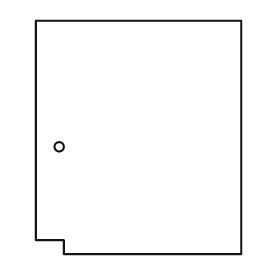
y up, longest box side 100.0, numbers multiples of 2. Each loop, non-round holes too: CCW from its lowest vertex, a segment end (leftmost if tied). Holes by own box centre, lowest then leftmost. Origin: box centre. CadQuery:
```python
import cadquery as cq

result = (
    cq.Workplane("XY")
    .moveTo(-32.0, -50.0)
    .lineTo(44.0, -50.0)
    .lineTo(44.0, 50.0)
    .lineTo(-44.0, 50.0)
    .lineTo(-44.0, -44.0)
    .lineTo(-32.0, -44.0)
    .close()
    .moveTo(-34.0, -4.0)
    .circle(2.0)
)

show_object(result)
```